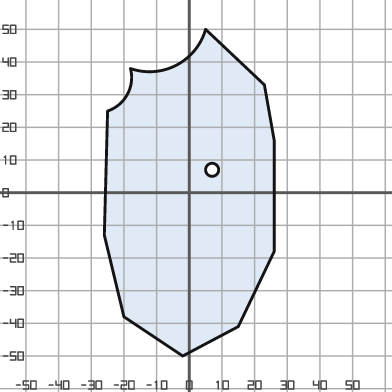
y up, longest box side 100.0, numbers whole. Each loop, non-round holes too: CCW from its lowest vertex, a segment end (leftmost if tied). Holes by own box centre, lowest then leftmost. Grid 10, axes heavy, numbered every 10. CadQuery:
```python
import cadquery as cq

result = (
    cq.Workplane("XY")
    .moveTo(-2.0, -50.0)
    .lineTo(15.0, -41.0)
    .lineTo(26.0, -18.0)
    .lineTo(26.0, 16.0)
    .lineTo(23.0, 33.0)
    .lineTo(5.0, 50.0)
    .threePointArc((-4.0, 39.0), (-18.0, 38.0))
    .threePointArc((-19.0, 30.0), (-25.0, 25.0))
    .lineTo(-26.0, -13.0)
    .lineTo(-20.0, -38.0)
    .close()
    .moveTo(7.0, 7.0)
    .circle(2.0)
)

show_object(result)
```